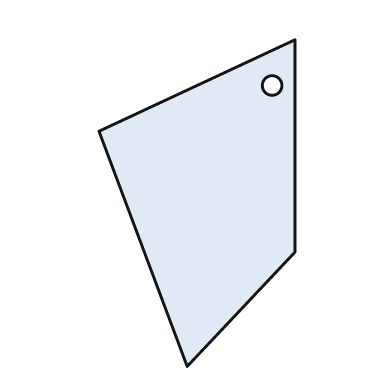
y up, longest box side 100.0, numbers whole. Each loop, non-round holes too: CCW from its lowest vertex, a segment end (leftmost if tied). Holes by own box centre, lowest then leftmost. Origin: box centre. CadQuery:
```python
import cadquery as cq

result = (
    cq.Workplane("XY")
    .moveTo(-3.0, -50.0)
    .lineTo(30.0, -15.0)
    .lineTo(30.0, 50.0)
    .lineTo(-30.0, 22.0)
    .close()
    .moveTo(23.0, 36.0)
    .circle(3.0)
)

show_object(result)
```